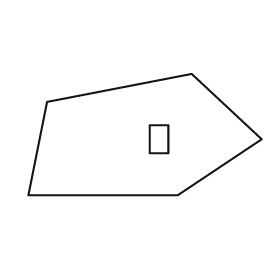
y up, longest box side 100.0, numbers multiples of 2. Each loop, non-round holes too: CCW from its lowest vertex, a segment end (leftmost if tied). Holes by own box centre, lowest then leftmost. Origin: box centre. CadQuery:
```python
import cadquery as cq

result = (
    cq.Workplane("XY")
    .moveTo(-50.0, -26.0)
    .lineTo(14.0, -26.0)
    .lineTo(50.0, -2.0)
    .lineTo(20.0, 26.0)
    .lineTo(-42.0, 14.0)
    .close()
    .moveTo(2.0, -8.0)
    .lineTo(10.0, -8.0)
    .lineTo(10.0, 4.0)
    .lineTo(2.0, 4.0)
    .close()
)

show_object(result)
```